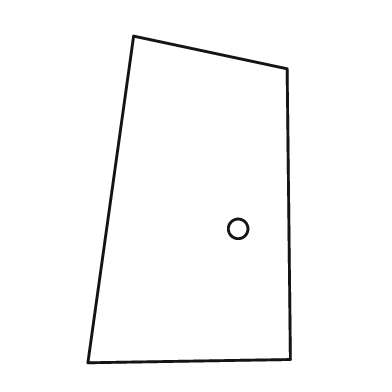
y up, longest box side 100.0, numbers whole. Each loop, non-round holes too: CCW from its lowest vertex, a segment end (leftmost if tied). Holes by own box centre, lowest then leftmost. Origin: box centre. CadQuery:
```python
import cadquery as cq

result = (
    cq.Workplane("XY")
    .moveTo(-31.0, -50.0)
    .lineTo(31.0, -49.0)
    .lineTo(30.0, 40.0)
    .lineTo(-17.0, 50.0)
    .close()
    .moveTo(15.0, -9.0)
    .circle(3.0)
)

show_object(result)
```